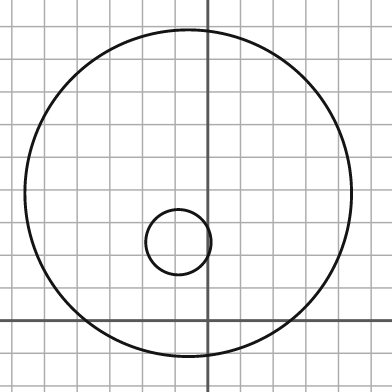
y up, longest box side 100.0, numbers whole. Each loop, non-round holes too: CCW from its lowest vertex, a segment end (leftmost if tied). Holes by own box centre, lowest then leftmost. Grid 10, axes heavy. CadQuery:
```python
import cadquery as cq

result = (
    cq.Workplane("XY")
    .moveTo(-6.0, 39.0)
    .circle(50.0)
    .moveTo(-9.0, 24.0)
    .circle(10.0)
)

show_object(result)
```